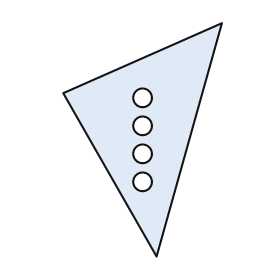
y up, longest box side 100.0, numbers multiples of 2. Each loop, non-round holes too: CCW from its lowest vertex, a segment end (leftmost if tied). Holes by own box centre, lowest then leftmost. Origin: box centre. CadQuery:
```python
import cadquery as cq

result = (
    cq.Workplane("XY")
    .moveTo(6.0, -50.0)
    .lineTo(34.0, 50.0)
    .lineTo(-34.0, 20.0)
    .close()
    .moveTo(0.0, -18.0)
    .circle(4.0)
    .moveTo(0.0, -6.0)
    .circle(4.0)
    .moveTo(0.0, 6.0)
    .circle(4.0)
    .moveTo(0.0, 18.0)
    .circle(4.0)
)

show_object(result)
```